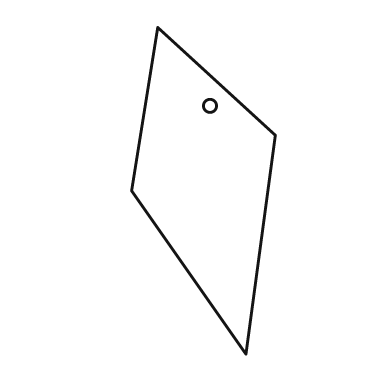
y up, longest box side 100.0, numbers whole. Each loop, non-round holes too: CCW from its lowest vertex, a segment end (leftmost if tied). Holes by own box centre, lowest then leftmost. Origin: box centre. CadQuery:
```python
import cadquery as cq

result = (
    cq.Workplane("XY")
    .moveTo(13.0, -50.0)
    .lineTo(22.0, 17.0)
    .lineTo(-14.0, 50.0)
    .lineTo(-22.0, 0.0)
    .close()
    .moveTo(2.0, 26.0)
    .circle(2.0)
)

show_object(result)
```